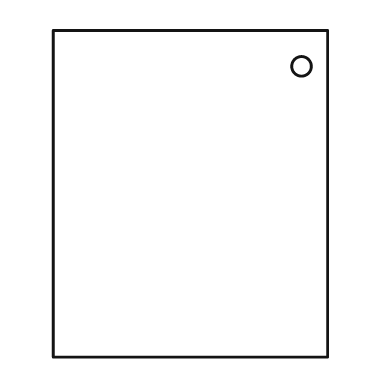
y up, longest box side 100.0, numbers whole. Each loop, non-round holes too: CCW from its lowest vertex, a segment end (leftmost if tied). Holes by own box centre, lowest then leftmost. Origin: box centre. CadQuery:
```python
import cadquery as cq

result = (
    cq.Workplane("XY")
    .moveTo(-42.0, -50.0)
    .lineTo(42.0, -50.0)
    .lineTo(42.0, 50.0)
    .lineTo(-42.0, 50.0)
    .close()
    .moveTo(34.0, 39.0)
    .circle(3.0)
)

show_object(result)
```